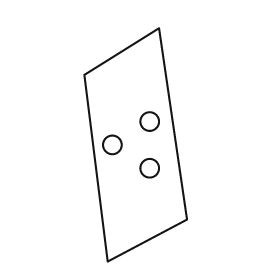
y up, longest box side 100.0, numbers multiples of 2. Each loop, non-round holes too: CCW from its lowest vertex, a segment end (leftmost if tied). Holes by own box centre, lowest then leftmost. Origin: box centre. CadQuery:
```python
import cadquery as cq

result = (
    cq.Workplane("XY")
    .moveTo(-12.0, -50.0)
    .lineTo(22.0, -32.0)
    .lineTo(10.0, 50.0)
    .lineTo(-22.0, 30.0)
    .close()
    .moveTo(6.0, -10.0)
    .circle(4.0)
    .moveTo(-10.0, 0.0)
    .circle(4.0)
    .moveTo(6.0, 10.0)
    .circle(4.0)
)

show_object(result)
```